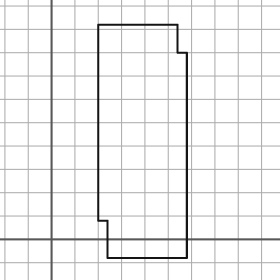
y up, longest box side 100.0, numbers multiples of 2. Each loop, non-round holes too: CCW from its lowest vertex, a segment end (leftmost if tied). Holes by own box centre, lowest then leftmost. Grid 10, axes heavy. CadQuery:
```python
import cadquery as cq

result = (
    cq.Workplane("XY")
    .moveTo(24.0, -8.0)
    .lineTo(58.0, -8.0)
    .lineTo(58.0, 80.0)
    .lineTo(54.0, 80.0)
    .lineTo(54.0, 92.0)
    .lineTo(20.0, 92.0)
    .lineTo(20.0, 8.0)
    .lineTo(24.0, 8.0)
    .close()
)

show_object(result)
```